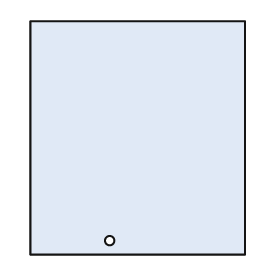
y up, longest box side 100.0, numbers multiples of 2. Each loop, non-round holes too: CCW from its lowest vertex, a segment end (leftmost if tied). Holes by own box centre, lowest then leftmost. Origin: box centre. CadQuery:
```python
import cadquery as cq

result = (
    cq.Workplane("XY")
    .moveTo(-46.0, -50.0)
    .lineTo(46.0, -50.0)
    .lineTo(46.0, 50.0)
    .lineTo(-46.0, 50.0)
    .close()
    .moveTo(-12.0, -44.0)
    .circle(2.0)
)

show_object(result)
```